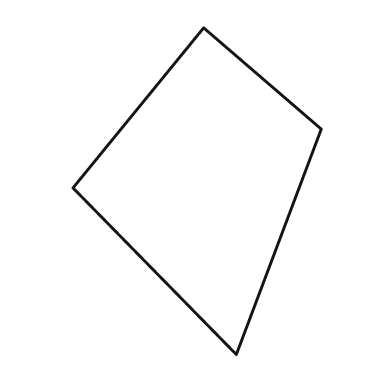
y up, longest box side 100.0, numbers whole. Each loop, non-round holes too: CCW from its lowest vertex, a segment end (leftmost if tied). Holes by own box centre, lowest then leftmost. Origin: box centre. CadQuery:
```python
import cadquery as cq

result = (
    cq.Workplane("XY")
    .moveTo(12.0, -50.0)
    .lineTo(38.0, 19.0)
    .lineTo(2.0, 50.0)
    .lineTo(-38.0, 1.0)
    .close()
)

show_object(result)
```